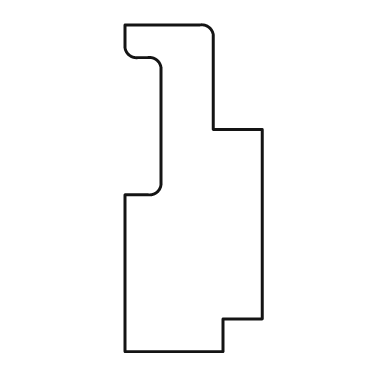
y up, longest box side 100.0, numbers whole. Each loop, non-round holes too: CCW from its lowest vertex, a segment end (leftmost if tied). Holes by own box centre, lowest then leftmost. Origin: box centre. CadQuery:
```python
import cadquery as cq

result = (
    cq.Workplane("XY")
    .moveTo(-21.0, -50.0)
    .lineTo(9.0, -50.0)
    .lineTo(9.0, -40.0)
    .lineTo(21.0, -40.0)
    .lineTo(21.0, 18.0)
    .lineTo(6.0, 18.0)
    .lineTo(6.0, 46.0)
    .threePointArc((5.0, 49.0), (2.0, 50.0))
    .lineTo(-21.0, 50.0)
    .lineTo(-21.0, 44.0)
    .threePointArc((-20.0, 41.0), (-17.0, 40.0))
    .lineTo(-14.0, 40.0)
    .threePointArc((-11.0, 39.0), (-10.0, 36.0))
    .lineTo(-10.0, 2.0)
    .threePointArc((-11.0, -1.0), (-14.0, -2.0))
    .lineTo(-21.0, -2.0)
    .close()
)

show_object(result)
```